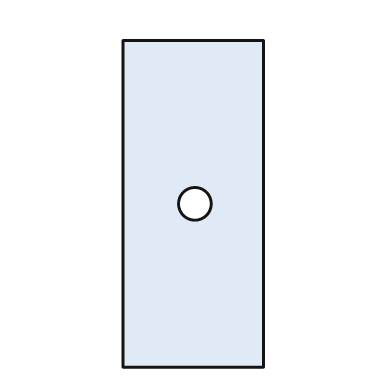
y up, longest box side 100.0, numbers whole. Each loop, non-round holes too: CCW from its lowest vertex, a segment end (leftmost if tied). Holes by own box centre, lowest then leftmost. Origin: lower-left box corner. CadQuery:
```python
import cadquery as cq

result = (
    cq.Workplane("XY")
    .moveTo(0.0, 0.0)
    .lineTo(43.0, 0.0)
    .lineTo(43.0, 100.0)
    .lineTo(0.0, 100.0)
    .close()
    .moveTo(22.0, 50.0)
    .circle(5.0)
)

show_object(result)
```